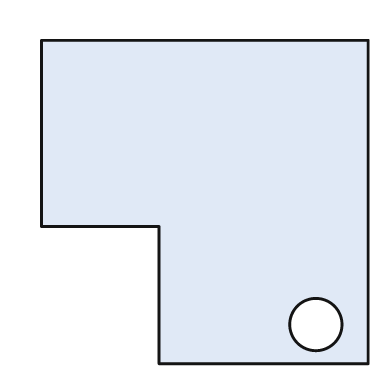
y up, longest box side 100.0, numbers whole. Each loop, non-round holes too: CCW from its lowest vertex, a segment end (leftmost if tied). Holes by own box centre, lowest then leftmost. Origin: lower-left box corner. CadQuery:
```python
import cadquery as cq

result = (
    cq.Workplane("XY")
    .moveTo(36.0, 0.0)
    .lineTo(100.0, 0.0)
    .lineTo(100.0, 99.0)
    .lineTo(0.0, 99.0)
    .lineTo(0.0, 42.0)
    .lineTo(36.0, 42.0)
    .close()
    .moveTo(84.0, 12.0)
    .circle(8.0)
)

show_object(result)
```